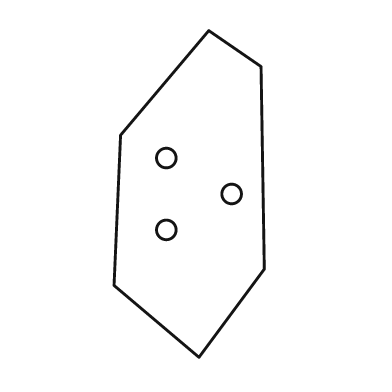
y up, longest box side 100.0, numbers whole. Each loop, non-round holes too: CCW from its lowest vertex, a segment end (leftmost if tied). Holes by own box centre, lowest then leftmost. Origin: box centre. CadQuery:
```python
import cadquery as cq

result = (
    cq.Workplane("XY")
    .moveTo(3.0, -50.0)
    .lineTo(23.0, -23.0)
    .lineTo(22.0, 39.0)
    .lineTo(6.0, 50.0)
    .lineTo(-21.0, 18.0)
    .lineTo(-23.0, -28.0)
    .close()
    .moveTo(-7.0, -11.0)
    .circle(3.0)
    .moveTo(13.0, 0.0)
    .circle(3.0)
    .moveTo(-7.0, 11.0)
    .circle(3.0)
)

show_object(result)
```